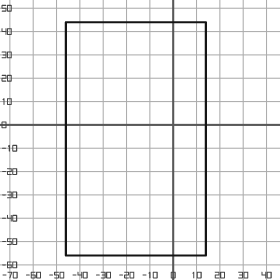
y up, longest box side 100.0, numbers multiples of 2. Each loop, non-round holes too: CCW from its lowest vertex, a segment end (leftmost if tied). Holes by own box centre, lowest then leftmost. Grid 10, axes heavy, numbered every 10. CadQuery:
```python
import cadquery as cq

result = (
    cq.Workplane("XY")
    .moveTo(-46.0, -56.0)
    .lineTo(14.0, -56.0)
    .lineTo(14.0, 44.0)
    .lineTo(-46.0, 44.0)
    .close()
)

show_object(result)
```